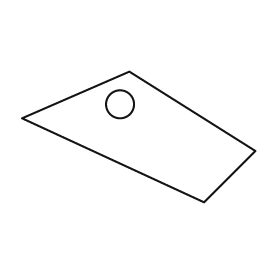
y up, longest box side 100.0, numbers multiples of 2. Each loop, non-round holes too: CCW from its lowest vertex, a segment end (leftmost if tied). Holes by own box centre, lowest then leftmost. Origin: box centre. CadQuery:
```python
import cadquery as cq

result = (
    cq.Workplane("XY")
    .moveTo(28.0, -28.0)
    .lineTo(50.0, -6.0)
    .lineTo(-4.0, 28.0)
    .lineTo(-50.0, 8.0)
    .close()
    .moveTo(-8.0, 14.0)
    .circle(6.0)
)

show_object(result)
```